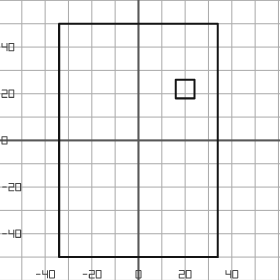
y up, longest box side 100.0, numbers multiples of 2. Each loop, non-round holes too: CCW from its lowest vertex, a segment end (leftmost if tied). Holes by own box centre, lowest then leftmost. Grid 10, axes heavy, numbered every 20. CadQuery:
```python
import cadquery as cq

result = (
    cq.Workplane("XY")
    .moveTo(-34.0, -50.0)
    .lineTo(34.0, -50.0)
    .lineTo(34.0, 50.0)
    .lineTo(-34.0, 50.0)
    .close()
    .moveTo(16.0, 18.0)
    .lineTo(24.0, 18.0)
    .lineTo(24.0, 26.0)
    .lineTo(16.0, 26.0)
    .close()
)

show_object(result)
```